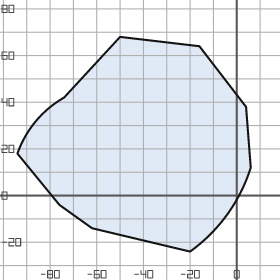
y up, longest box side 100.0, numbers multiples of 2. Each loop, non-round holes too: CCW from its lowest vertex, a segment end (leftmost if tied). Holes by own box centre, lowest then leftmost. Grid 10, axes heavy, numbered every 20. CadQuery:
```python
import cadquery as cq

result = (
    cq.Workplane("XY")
    .moveTo(-20.0, -24.0)
    .threePointArc((-4.0, -8.0), (6.0, 12.0))
    .lineTo(4.0, 38.0)
    .lineTo(-16.0, 64.0)
    .lineTo(-50.0, 68.0)
    .lineTo(-74.0, 42.0)
    .threePointArc((-86.0, 32.0), (-94.0, 18.0))
    .lineTo(-76.0, -4.0)
    .lineTo(-62.0, -14.0)
    .close()
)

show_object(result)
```